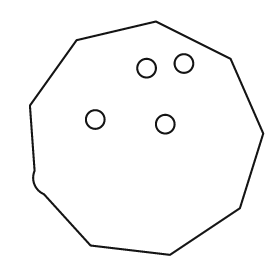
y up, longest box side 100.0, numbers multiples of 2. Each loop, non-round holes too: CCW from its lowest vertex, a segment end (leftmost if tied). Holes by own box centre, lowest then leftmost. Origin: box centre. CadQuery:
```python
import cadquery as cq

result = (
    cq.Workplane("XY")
    .moveTo(10.0, -50.0)
    .lineTo(40.0, -30.0)
    .lineTo(50.0, 2.0)
    .lineTo(36.0, 34.0)
    .lineTo(4.0, 50.0)
    .lineTo(-30.0, 42.0)
    .lineTo(-50.0, 14.0)
    .lineTo(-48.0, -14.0)
    .threePointArc((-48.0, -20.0), (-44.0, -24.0))
    .lineTo(-24.0, -46.0)
    .close()
    .moveTo(8.0, 6.0)
    .circle(4.0)
    .moveTo(-22.0, 8.0)
    .circle(4.0)
    .moveTo(0.0, 30.0)
    .circle(4.0)
    .moveTo(16.0, 32.0)
    .circle(4.0)
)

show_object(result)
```